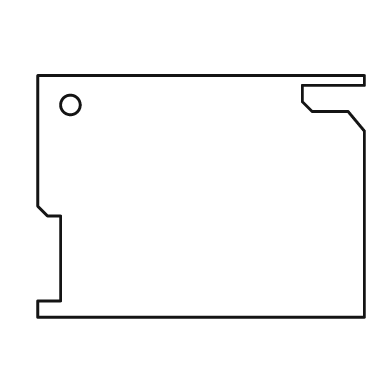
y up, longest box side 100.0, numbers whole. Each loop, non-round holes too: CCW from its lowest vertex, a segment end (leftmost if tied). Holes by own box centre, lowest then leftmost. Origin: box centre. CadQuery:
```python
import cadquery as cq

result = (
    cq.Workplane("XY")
    .moveTo(-50.0, -37.0)
    .lineTo(50.0, -37.0)
    .lineTo(50.0, 20.0)
    .lineTo(45.0, 26.0)
    .lineTo(34.0, 26.0)
    .lineTo(31.0, 29.0)
    .lineTo(31.0, 34.0)
    .lineTo(50.0, 34.0)
    .lineTo(50.0, 37.0)
    .lineTo(-50.0, 37.0)
    .lineTo(-50.0, -3.0)
    .lineTo(-47.0, -6.0)
    .lineTo(-43.0, -6.0)
    .lineTo(-43.0, -32.0)
    .lineTo(-50.0, -32.0)
    .close()
    .moveTo(-40.0, 28.0)
    .circle(3.0)
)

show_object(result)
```